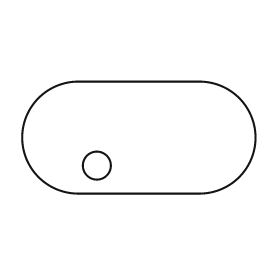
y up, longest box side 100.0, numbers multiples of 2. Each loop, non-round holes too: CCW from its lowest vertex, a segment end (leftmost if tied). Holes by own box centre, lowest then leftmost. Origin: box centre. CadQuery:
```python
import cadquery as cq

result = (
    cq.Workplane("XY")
    .moveTo(-26.0, -24.0)
    .lineTo(26.0, -24.0)
    .threePointArc((50.0, 0.0), (26.0, 24.0))
    .lineTo(-26.0, 24.0)
    .threePointArc((-50.0, 0.0), (-26.0, -24.0))
    .close()
    .moveTo(-18.0, -12.0)
    .circle(6.0)
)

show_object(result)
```